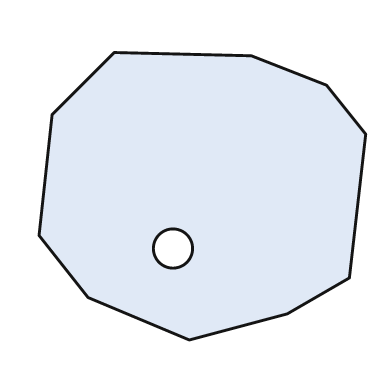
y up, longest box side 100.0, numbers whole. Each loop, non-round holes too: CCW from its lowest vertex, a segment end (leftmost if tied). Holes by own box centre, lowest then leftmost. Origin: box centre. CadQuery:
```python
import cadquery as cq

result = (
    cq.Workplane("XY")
    .moveTo(-4.0, -44.0)
    .lineTo(26.0, -36.0)
    .lineTo(45.0, -25.0)
    .lineTo(50.0, 19.0)
    .lineTo(38.0, 34.0)
    .lineTo(15.0, 43.0)
    .lineTo(-27.0, 44.0)
    .lineTo(-46.0, 25.0)
    .lineTo(-50.0, -12.0)
    .lineTo(-35.0, -31.0)
    .close()
    .moveTo(-9.0, -16.0)
    .circle(6.0)
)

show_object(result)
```